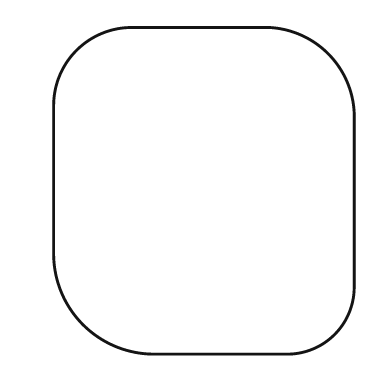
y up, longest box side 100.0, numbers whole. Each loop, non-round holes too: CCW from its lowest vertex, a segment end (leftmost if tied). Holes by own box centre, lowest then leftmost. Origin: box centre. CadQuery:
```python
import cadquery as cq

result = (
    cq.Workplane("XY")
    .moveTo(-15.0, -50.0)
    .lineTo(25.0, -50.0)
    .threePointArc((40.0, -44.0), (46.0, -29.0))
    .lineTo(46.0, 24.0)
    .threePointArc((38.0, 42.0), (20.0, 50.0))
    .lineTo(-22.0, 50.0)
    .threePointArc((-39.0, 43.0), (-46.0, 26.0))
    .lineTo(-46.0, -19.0)
    .threePointArc((-37.0, -41.0), (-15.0, -50.0))
    .close()
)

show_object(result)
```